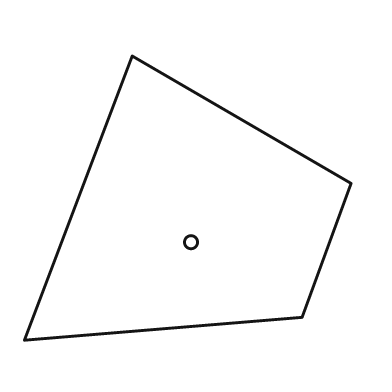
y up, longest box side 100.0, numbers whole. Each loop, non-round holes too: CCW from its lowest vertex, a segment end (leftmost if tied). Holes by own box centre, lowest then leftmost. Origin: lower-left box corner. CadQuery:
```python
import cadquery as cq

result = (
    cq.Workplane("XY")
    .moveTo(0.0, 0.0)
    .lineTo(85.0, 7.0)
    .lineTo(100.0, 48.0)
    .lineTo(33.0, 87.0)
    .close()
    .moveTo(51.0, 30.0)
    .circle(2.0)
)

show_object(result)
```